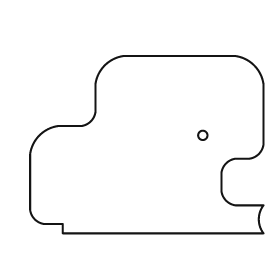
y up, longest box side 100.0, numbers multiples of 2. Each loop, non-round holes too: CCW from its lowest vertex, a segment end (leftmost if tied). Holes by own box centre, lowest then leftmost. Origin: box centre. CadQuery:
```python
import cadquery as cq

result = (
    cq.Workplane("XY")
    .moveTo(-36.0, -38.0)
    .lineTo(50.0, -38.0)
    .threePointArc((48.0, -32.0), (50.0, -26.0))
    .lineTo(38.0, -26.0)
    .threePointArc((34.0, -24.0), (32.0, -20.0))
    .lineTo(32.0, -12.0)
    .threePointArc((34.0, -8.0), (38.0, -6.0))
    .lineTo(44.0, -6.0)
    .threePointArc((48.0, -4.0), (50.0, 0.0))
    .lineTo(50.0, 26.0)
    .threePointArc((46.0, 34.0), (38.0, 38.0))
    .lineTo(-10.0, 38.0)
    .threePointArc((-18.0, 34.0), (-22.0, 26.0))
    .lineTo(-22.0, 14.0)
    .threePointArc((-24.0, 10.0), (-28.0, 8.0))
    .lineTo(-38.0, 8.0)
    .threePointArc((-46.0, 4.0), (-50.0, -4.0))
    .lineTo(-50.0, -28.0)
    .threePointArc((-48.0, -32.0), (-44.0, -34.0))
    .lineTo(-36.0, -34.0)
    .close()
    .moveTo(24.0, 4.0)
    .circle(2.0)
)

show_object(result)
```